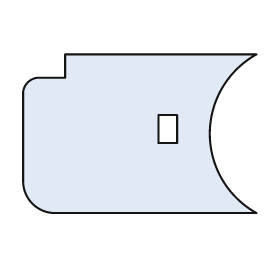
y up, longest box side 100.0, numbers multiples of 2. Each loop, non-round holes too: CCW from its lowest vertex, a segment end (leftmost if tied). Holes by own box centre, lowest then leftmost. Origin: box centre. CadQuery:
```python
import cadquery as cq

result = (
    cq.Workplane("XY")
    .moveTo(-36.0, -34.0)
    .lineTo(50.0, -34.0)
    .threePointArc((30.0, 0.0), (50.0, 34.0))
    .lineTo(-32.0, 34.0)
    .lineTo(-32.0, 24.0)
    .lineTo(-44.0, 24.0)
    .threePointArc((-48.0, 22.0), (-50.0, 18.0))
    .lineTo(-50.0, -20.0)
    .threePointArc((-46.0, -30.0), (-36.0, -34.0))
    .close()
    .moveTo(8.0, -4.0)
    .lineTo(16.0, -4.0)
    .lineTo(16.0, 8.0)
    .lineTo(8.0, 8.0)
    .close()
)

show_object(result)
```